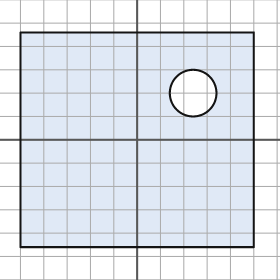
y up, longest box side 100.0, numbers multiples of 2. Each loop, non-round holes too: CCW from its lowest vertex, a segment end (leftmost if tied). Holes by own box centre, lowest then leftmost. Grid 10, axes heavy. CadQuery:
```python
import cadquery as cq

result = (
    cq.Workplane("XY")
    .moveTo(-50.0, -46.0)
    .lineTo(50.0, -46.0)
    .lineTo(50.0, 46.0)
    .lineTo(-50.0, 46.0)
    .close()
    .moveTo(24.0, 20.0)
    .circle(10.0)
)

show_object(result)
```